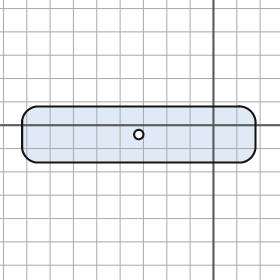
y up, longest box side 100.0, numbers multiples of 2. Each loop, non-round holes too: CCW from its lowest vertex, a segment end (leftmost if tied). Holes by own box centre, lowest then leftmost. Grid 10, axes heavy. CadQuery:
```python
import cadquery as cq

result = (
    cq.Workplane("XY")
    .moveTo(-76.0, -16.0)
    .lineTo(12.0, -16.0)
    .threePointArc((16.0, -14.0), (18.0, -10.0))
    .lineTo(18.0, 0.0)
    .threePointArc((16.0, 6.0), (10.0, 8.0))
    .lineTo(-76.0, 8.0)
    .threePointArc((-80.0, 6.0), (-82.0, 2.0))
    .lineTo(-82.0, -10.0)
    .threePointArc((-80.0, -14.0), (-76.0, -16.0))
    .close()
    .moveTo(-32.0, -4.0)
    .circle(2.0)
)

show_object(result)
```